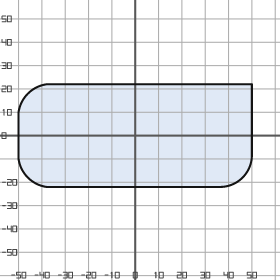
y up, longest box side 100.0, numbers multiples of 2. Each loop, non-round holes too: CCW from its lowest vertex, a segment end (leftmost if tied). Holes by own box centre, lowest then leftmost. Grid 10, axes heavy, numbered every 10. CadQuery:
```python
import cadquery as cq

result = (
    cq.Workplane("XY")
    .moveTo(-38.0, -22.0)
    .lineTo(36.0, -22.0)
    .threePointArc((46.0, -18.0), (50.0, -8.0))
    .lineTo(50.0, 22.0)
    .lineTo(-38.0, 22.0)
    .threePointArc((-46.0, 18.0), (-50.0, 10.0))
    .lineTo(-50.0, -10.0)
    .threePointArc((-46.0, -18.0), (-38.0, -22.0))
    .close()
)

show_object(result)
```